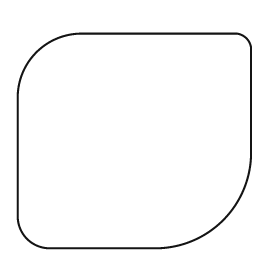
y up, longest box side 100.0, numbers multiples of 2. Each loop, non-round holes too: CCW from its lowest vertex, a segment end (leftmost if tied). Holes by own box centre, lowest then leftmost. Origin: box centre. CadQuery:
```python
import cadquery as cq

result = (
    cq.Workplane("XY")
    .moveTo(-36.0, -46.0)
    .lineTo(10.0, -46.0)
    .threePointArc((38.0, -34.0), (50.0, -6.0))
    .lineTo(50.0, 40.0)
    .threePointArc((48.0, 44.0), (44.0, 46.0))
    .lineTo(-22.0, 46.0)
    .threePointArc((-42.0, 38.0), (-50.0, 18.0))
    .lineTo(-50.0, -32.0)
    .threePointArc((-46.0, -42.0), (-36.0, -46.0))
    .close()
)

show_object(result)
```